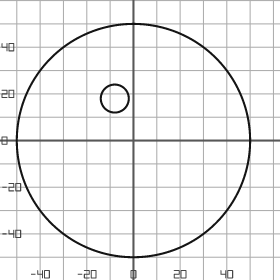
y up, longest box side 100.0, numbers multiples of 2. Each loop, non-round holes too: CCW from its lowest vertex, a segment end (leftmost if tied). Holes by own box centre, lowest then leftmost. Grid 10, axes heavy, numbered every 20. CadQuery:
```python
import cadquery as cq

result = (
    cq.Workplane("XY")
    .moveTo(0.0, 0.0)
    .circle(50.0)
    .moveTo(-8.0, 18.0)
    .circle(6.0)
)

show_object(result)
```